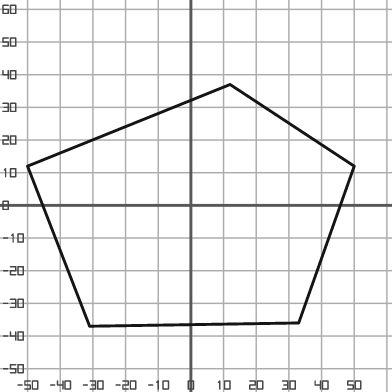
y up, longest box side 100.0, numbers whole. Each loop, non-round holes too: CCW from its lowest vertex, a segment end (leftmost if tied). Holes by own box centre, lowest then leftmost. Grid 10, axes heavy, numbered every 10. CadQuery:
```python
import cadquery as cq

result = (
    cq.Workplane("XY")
    .moveTo(-31.0, -37.0)
    .lineTo(33.0, -36.0)
    .lineTo(50.0, 12.0)
    .lineTo(12.0, 37.0)
    .lineTo(-50.0, 12.0)
    .close()
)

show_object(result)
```